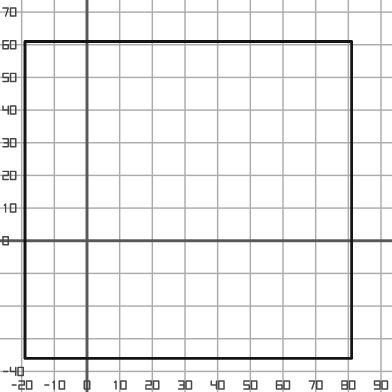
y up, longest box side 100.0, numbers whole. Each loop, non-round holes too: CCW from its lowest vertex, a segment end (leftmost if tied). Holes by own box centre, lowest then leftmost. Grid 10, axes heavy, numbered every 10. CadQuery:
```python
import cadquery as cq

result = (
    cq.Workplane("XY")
    .moveTo(-19.0, -36.0)
    .lineTo(81.0, -36.0)
    .lineTo(81.0, 61.0)
    .lineTo(-19.0, 61.0)
    .close()
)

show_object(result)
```